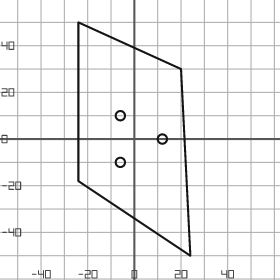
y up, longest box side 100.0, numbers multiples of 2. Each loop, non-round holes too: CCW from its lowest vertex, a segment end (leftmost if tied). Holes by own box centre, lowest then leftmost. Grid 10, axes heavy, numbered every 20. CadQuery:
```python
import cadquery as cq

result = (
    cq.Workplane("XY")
    .moveTo(24.0, -50.0)
    .lineTo(20.0, 30.0)
    .lineTo(-24.0, 50.0)
    .lineTo(-24.0, -18.0)
    .close()
    .moveTo(-6.0, -10.0)
    .circle(2.0)
    .moveTo(12.0, 0.0)
    .circle(2.0)
    .moveTo(-6.0, 10.0)
    .circle(2.0)
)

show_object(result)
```